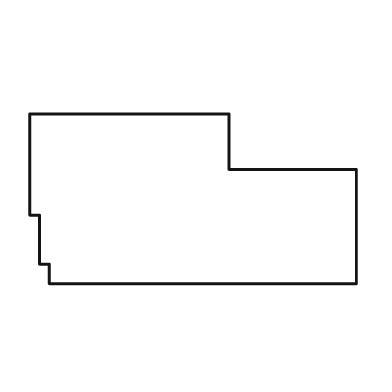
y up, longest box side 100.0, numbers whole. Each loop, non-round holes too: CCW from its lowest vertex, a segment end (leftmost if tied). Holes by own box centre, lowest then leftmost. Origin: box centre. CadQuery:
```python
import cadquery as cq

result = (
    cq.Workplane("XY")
    .moveTo(-44.0, -26.0)
    .lineTo(50.0, -26.0)
    .lineTo(50.0, 9.0)
    .lineTo(11.0, 9.0)
    .lineTo(11.0, 26.0)
    .lineTo(-50.0, 26.0)
    .lineTo(-50.0, -5.0)
    .lineTo(-47.0, -5.0)
    .lineTo(-47.0, -20.0)
    .lineTo(-44.0, -20.0)
    .close()
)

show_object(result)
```